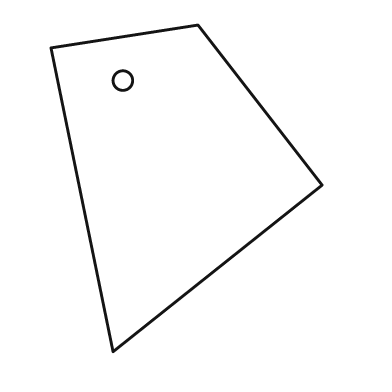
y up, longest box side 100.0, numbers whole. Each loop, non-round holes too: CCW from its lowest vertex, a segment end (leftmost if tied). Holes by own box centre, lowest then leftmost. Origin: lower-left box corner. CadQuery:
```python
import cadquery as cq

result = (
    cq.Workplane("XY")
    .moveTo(19.0, 0.0)
    .lineTo(83.0, 51.0)
    .lineTo(45.0, 100.0)
    .lineTo(0.0, 93.0)
    .close()
    .moveTo(22.0, 83.0)
    .circle(3.0)
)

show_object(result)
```